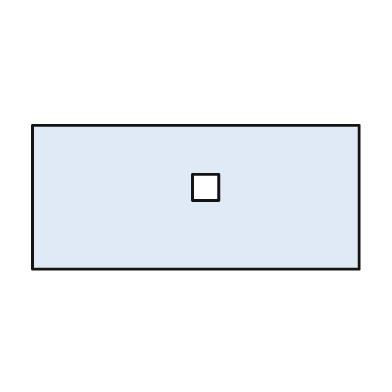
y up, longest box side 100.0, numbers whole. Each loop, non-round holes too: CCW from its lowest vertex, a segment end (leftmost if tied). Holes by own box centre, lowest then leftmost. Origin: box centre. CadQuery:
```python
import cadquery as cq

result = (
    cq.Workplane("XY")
    .moveTo(-50.0, -22.0)
    .lineTo(50.0, -22.0)
    .lineTo(50.0, 22.0)
    .lineTo(-50.0, 22.0)
    .close()
    .moveTo(-1.0, -1.0)
    .lineTo(7.0, -1.0)
    .lineTo(7.0, 7.0)
    .lineTo(-1.0, 7.0)
    .close()
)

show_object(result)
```